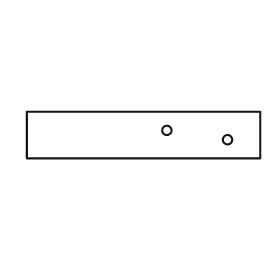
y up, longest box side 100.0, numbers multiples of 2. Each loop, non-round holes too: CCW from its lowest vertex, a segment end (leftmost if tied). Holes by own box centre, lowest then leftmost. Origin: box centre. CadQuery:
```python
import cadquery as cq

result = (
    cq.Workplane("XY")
    .moveTo(-50.0, -10.0)
    .lineTo(50.0, -10.0)
    .lineTo(50.0, 10.0)
    .lineTo(-50.0, 10.0)
    .close()
    .moveTo(36.0, -2.0)
    .circle(2.0)
    .moveTo(10.0, 2.0)
    .circle(2.0)
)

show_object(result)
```